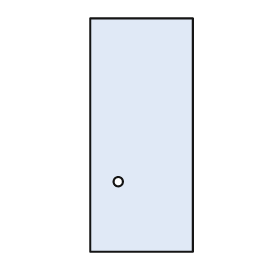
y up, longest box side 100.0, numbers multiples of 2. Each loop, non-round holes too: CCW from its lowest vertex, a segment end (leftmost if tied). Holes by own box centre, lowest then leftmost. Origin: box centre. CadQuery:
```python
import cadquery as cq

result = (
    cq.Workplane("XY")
    .moveTo(-22.0, -50.0)
    .lineTo(22.0, -50.0)
    .lineTo(22.0, 50.0)
    .lineTo(-22.0, 50.0)
    .close()
    .moveTo(-10.0, -20.0)
    .circle(2.0)
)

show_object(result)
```